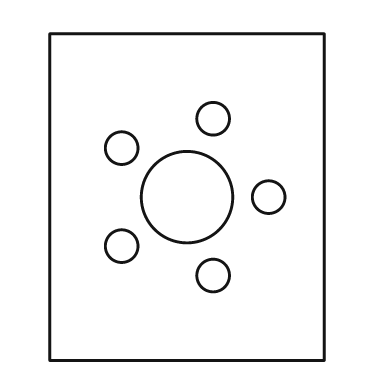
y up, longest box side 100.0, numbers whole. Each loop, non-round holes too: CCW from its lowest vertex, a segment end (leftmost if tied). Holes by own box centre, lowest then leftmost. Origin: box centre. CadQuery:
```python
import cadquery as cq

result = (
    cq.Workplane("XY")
    .moveTo(-42.0, -50.0)
    .lineTo(42.0, -50.0)
    .lineTo(42.0, 50.0)
    .lineTo(-42.0, 50.0)
    .close()
    .moveTo(8.0, -24.0)
    .circle(5.0)
    .moveTo(-20.0, -15.0)
    .circle(5.0)
    .moveTo(0.0, 0.0)
    .circle(14.0)
    .moveTo(25.0, 0.0)
    .circle(5.0)
    .moveTo(-20.0, 15.0)
    .circle(5.0)
    .moveTo(8.0, 24.0)
    .circle(5.0)
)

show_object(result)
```